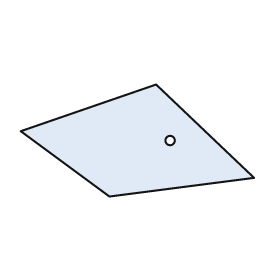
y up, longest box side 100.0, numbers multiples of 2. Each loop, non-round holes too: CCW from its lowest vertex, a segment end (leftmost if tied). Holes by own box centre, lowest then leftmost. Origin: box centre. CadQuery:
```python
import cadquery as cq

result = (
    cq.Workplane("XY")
    .moveTo(-12.0, -24.0)
    .lineTo(50.0, -16.0)
    .lineTo(8.0, 24.0)
    .lineTo(-50.0, 4.0)
    .close()
    .moveTo(14.0, 0.0)
    .circle(2.0)
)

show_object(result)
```